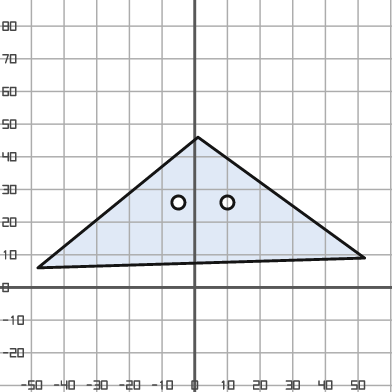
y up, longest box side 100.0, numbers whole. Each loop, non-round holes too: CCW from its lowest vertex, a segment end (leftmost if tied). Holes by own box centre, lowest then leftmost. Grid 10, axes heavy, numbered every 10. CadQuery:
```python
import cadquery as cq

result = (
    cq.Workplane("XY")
    .moveTo(-48.0, 6.0)
    .lineTo(52.0, 9.0)
    .lineTo(1.0, 46.0)
    .close()
    .moveTo(-5.0, 26.0)
    .circle(2.0)
    .moveTo(10.0, 26.0)
    .circle(2.0)
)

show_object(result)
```